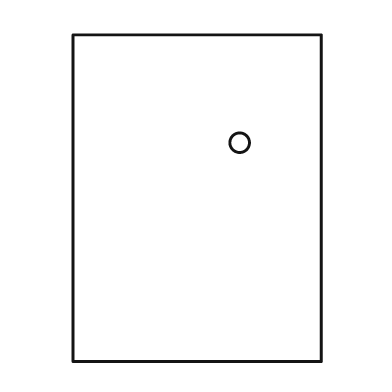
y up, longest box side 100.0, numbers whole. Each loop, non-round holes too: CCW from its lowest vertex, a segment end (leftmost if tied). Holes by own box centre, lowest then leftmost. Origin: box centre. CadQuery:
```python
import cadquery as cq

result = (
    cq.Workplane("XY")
    .moveTo(-38.0, -50.0)
    .lineTo(38.0, -50.0)
    .lineTo(38.0, 50.0)
    .lineTo(-38.0, 50.0)
    .close()
    .moveTo(13.0, 17.0)
    .circle(3.0)
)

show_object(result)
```